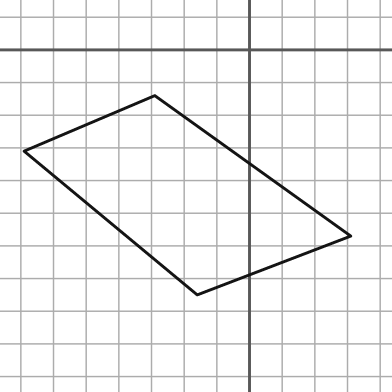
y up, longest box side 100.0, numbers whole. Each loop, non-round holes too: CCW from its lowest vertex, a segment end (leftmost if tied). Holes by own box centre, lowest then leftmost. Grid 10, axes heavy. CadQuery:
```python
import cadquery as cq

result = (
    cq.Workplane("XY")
    .moveTo(-16.0, -75.0)
    .lineTo(31.0, -57.0)
    .lineTo(-29.0, -14.0)
    .lineTo(-69.0, -31.0)
    .close()
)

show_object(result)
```